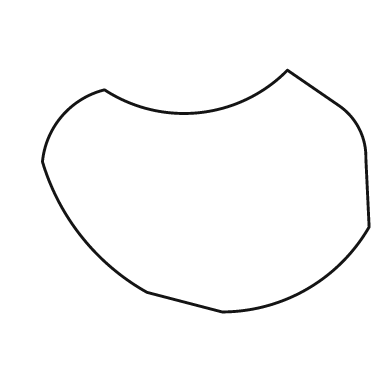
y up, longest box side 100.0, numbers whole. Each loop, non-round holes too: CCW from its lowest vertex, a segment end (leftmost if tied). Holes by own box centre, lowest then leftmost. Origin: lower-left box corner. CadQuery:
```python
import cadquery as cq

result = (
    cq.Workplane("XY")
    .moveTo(55.0, 0.0)
    .threePointArc((81.0, 7.0), (100.0, 26.0))
    .lineTo(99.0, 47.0)
    .threePointArc((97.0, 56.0), (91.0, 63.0))
    .lineTo(75.0, 74.0)
    .threePointArc((48.0, 61.0), (19.0, 68.0))
    .threePointArc((6.0, 60.0), (0.0, 46.0))
    .threePointArc((12.0, 23.0), (32.0, 6.0))
    .close()
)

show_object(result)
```